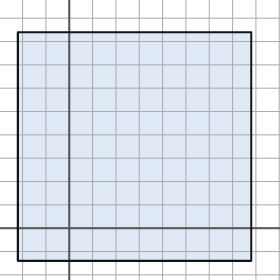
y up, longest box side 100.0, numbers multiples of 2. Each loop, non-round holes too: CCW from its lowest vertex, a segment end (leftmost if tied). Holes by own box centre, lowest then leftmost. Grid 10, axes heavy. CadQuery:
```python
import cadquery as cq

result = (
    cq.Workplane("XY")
    .moveTo(-22.0, -14.0)
    .lineTo(78.0, -14.0)
    .lineTo(78.0, 84.0)
    .lineTo(-22.0, 84.0)
    .close()
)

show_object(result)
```